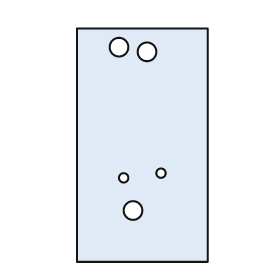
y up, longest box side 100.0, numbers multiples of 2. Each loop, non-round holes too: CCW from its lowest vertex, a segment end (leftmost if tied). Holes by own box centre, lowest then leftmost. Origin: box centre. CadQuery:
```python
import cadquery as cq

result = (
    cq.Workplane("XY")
    .moveTo(-28.0, -50.0)
    .lineTo(28.0, -50.0)
    .lineTo(28.0, 50.0)
    .lineTo(-28.0, 50.0)
    .close()
    .moveTo(-4.0, -28.0)
    .circle(4.0)
    .moveTo(-8.0, -14.0)
    .circle(2.0)
    .moveTo(8.0, -12.0)
    .circle(2.0)
    .moveTo(2.0, 40.0)
    .circle(4.0)
    .moveTo(-10.0, 42.0)
    .circle(4.0)
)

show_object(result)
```